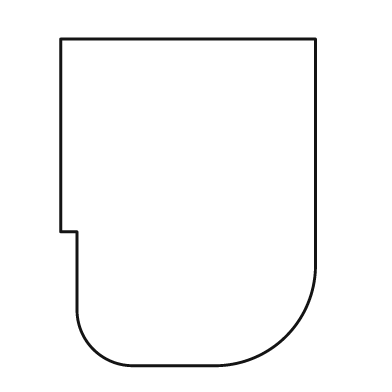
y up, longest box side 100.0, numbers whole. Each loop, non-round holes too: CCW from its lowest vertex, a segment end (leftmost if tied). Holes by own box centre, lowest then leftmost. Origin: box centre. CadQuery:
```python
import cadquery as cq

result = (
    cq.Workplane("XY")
    .moveTo(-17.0, -50.0)
    .lineTo(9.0, -50.0)
    .threePointArc((30.0, -41.0), (39.0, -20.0))
    .lineTo(39.0, 50.0)
    .lineTo(-39.0, 50.0)
    .lineTo(-39.0, -9.0)
    .lineTo(-34.0, -9.0)
    .lineTo(-34.0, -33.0)
    .threePointArc((-29.0, -45.0), (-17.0, -50.0))
    .close()
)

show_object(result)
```